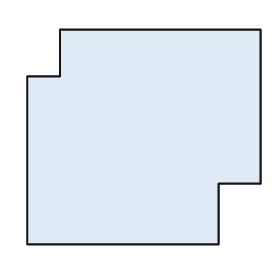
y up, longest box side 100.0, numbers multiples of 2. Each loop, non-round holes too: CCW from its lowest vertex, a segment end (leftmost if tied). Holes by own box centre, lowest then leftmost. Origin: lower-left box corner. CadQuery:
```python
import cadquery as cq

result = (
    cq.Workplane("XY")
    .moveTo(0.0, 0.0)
    .lineTo(82.0, 0.0)
    .lineTo(82.0, 26.0)
    .lineTo(100.0, 26.0)
    .lineTo(100.0, 92.0)
    .lineTo(14.0, 92.0)
    .lineTo(14.0, 72.0)
    .lineTo(0.0, 72.0)
    .close()
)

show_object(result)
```